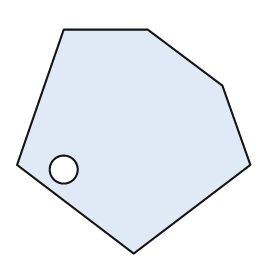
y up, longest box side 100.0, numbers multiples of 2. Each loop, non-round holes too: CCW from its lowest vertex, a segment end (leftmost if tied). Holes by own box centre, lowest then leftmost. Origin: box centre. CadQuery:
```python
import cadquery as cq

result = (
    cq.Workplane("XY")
    .moveTo(0.0, -48.0)
    .lineTo(50.0, -10.0)
    .lineTo(38.0, 24.0)
    .lineTo(6.0, 48.0)
    .lineTo(-30.0, 48.0)
    .lineTo(-50.0, -10.0)
    .close()
    .moveTo(-30.0, -12.0)
    .circle(6.0)
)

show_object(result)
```